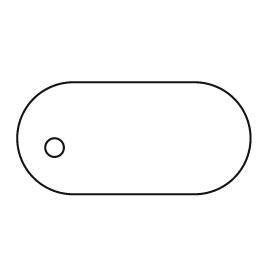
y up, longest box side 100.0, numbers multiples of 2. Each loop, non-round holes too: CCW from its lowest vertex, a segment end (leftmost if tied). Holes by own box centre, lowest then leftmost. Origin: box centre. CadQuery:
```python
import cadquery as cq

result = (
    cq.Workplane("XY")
    .moveTo(-26.0, -24.0)
    .lineTo(26.0, -24.0)
    .threePointArc((50.0, 0.0), (26.0, 24.0))
    .lineTo(-26.0, 24.0)
    .threePointArc((-50.0, 0.0), (-26.0, -24.0))
    .close()
    .moveTo(-34.0, -4.0)
    .circle(4.0)
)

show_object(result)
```